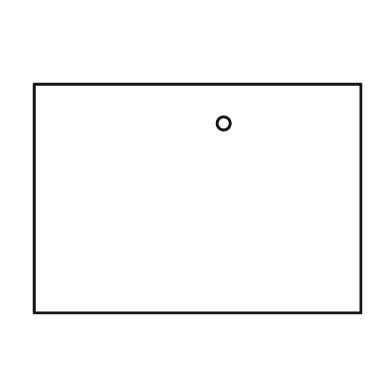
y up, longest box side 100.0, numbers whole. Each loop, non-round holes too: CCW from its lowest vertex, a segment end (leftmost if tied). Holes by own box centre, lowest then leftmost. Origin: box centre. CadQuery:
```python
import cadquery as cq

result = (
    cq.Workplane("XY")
    .moveTo(-50.0, -35.0)
    .lineTo(50.0, -35.0)
    .lineTo(50.0, 35.0)
    .lineTo(-50.0, 35.0)
    .close()
    .moveTo(8.0, 23.0)
    .circle(2.0)
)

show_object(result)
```